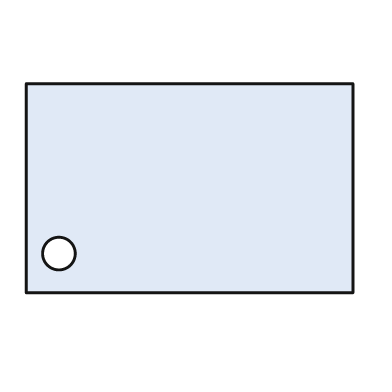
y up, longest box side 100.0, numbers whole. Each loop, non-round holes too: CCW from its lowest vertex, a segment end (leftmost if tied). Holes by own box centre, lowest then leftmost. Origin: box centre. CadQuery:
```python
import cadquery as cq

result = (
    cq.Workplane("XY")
    .moveTo(-50.0, -32.0)
    .lineTo(50.0, -32.0)
    .lineTo(50.0, 32.0)
    .lineTo(-50.0, 32.0)
    .close()
    .moveTo(-40.0, -20.0)
    .circle(5.0)
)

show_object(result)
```